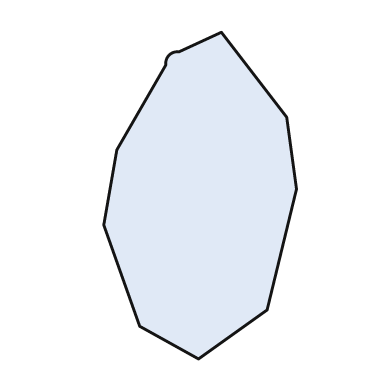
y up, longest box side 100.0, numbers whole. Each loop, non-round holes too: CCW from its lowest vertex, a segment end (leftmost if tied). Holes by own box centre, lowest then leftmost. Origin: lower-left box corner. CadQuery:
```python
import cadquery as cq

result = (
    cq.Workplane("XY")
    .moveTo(29.0, 0.0)
    .lineTo(50.0, 15.0)
    .lineTo(59.0, 52.0)
    .lineTo(56.0, 74.0)
    .lineTo(36.0, 100.0)
    .lineTo(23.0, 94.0)
    .threePointArc((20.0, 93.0), (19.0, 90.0))
    .lineTo(4.0, 64.0)
    .lineTo(0.0, 41.0)
    .lineTo(11.0, 10.0)
    .close()
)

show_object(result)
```